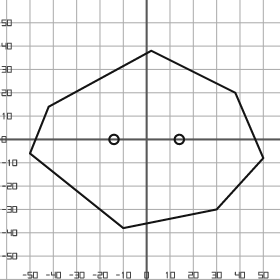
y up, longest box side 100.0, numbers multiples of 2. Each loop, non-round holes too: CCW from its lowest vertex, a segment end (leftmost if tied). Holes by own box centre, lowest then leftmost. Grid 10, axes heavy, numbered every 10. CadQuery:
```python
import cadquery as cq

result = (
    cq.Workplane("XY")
    .moveTo(-10.0, -38.0)
    .lineTo(30.0, -30.0)
    .lineTo(50.0, -8.0)
    .lineTo(38.0, 20.0)
    .lineTo(2.0, 38.0)
    .lineTo(-42.0, 14.0)
    .lineTo(-50.0, -6.0)
    .close()
    .moveTo(-14.0, 0.0)
    .circle(2.0)
    .moveTo(14.0, 0.0)
    .circle(2.0)
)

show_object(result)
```